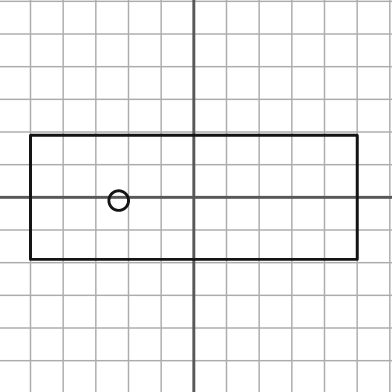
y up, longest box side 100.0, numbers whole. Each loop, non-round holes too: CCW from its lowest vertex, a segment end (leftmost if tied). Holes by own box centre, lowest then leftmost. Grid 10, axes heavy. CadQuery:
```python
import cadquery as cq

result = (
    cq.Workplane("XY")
    .moveTo(-50.0, -19.0)
    .lineTo(50.0, -19.0)
    .lineTo(50.0, 19.0)
    .lineTo(-50.0, 19.0)
    .close()
    .moveTo(-23.0, -1.0)
    .circle(3.0)
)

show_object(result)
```